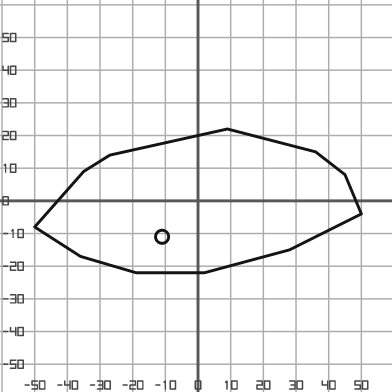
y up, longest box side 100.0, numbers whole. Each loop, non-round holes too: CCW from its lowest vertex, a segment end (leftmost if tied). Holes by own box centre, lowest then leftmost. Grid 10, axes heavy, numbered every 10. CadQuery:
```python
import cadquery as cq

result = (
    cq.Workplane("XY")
    .moveTo(-19.0, -22.0)
    .lineTo(2.0, -22.0)
    .lineTo(28.0, -15.0)
    .lineTo(50.0, -4.0)
    .lineTo(45.0, 8.0)
    .lineTo(36.0, 15.0)
    .lineTo(9.0, 22.0)
    .lineTo(-27.0, 14.0)
    .lineTo(-35.0, 9.0)
    .lineTo(-50.0, -8.0)
    .lineTo(-36.0, -17.0)
    .close()
    .moveTo(-11.0, -11.0)
    .circle(2.0)
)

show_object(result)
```